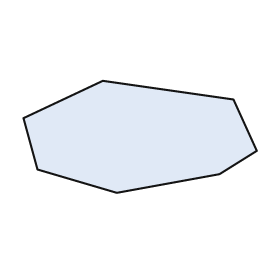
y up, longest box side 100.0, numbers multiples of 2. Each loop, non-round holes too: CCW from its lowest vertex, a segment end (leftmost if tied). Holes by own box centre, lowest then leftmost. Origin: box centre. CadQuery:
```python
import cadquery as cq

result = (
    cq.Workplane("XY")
    .moveTo(-10.0, -24.0)
    .lineTo(34.0, -16.0)
    .lineTo(50.0, -6.0)
    .lineTo(40.0, 16.0)
    .lineTo(-16.0, 24.0)
    .lineTo(-50.0, 8.0)
    .lineTo(-44.0, -14.0)
    .close()
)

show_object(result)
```